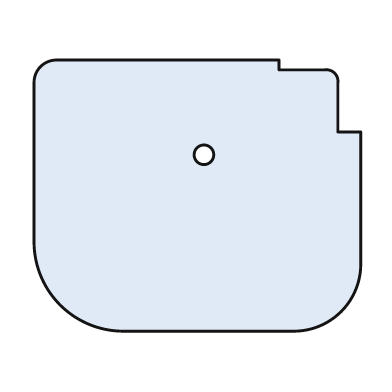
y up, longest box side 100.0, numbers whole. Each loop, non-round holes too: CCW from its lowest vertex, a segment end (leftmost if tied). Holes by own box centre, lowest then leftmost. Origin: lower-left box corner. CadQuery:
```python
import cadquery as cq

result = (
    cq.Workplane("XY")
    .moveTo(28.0, 0.0)
    .lineTo(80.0, 0.0)
    .threePointArc((94.0, 6.0), (100.0, 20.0))
    .lineTo(100.0, 61.0)
    .lineTo(93.0, 61.0)
    .lineTo(93.0, 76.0)
    .threePointArc((92.0, 79.0), (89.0, 80.0))
    .lineTo(75.0, 80.0)
    .lineTo(75.0, 83.0)
    .lineTo(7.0, 83.0)
    .threePointArc((2.0, 81.0), (0.0, 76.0))
    .lineTo(0.0, 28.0)
    .threePointArc((8.0, 8.0), (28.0, 0.0))
    .close()
    .moveTo(52.0, 54.0)
    .circle(3.0)
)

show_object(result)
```